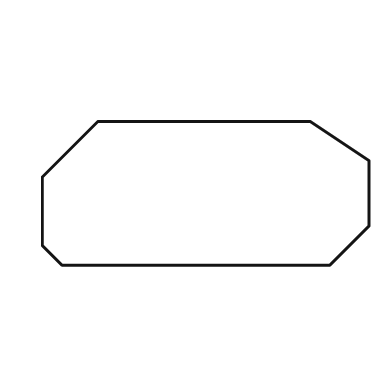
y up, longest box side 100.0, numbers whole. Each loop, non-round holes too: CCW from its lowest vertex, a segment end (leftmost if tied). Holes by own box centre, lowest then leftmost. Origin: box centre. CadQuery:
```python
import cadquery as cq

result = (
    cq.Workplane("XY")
    .moveTo(-44.0, -22.0)
    .lineTo(38.0, -22.0)
    .lineTo(50.0, -10.0)
    .lineTo(50.0, 10.0)
    .lineTo(32.0, 22.0)
    .lineTo(-33.0, 22.0)
    .lineTo(-50.0, 5.0)
    .lineTo(-50.0, -16.0)
    .close()
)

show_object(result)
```